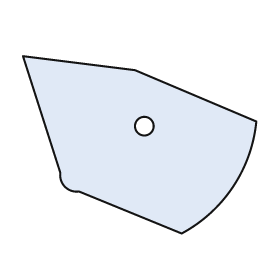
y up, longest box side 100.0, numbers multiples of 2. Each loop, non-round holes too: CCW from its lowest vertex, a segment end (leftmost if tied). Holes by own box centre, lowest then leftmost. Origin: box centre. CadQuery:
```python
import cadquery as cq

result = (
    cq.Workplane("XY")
    .moveTo(18.0, -38.0)
    .threePointArc((40.0, -18.0), (50.0, 10.0))
    .lineTo(-2.0, 32.0)
    .lineTo(-50.0, 38.0)
    .lineTo(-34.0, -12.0)
    .threePointArc((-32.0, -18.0), (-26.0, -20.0))
    .close()
    .moveTo(2.0, 8.0)
    .circle(4.0)
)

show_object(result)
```